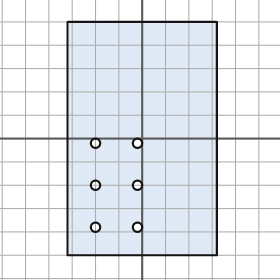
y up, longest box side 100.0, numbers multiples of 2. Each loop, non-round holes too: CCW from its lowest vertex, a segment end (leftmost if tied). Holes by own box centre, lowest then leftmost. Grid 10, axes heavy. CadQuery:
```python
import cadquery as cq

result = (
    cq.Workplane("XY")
    .moveTo(-32.0, -50.0)
    .lineTo(32.0, -50.0)
    .lineTo(32.0, 50.0)
    .lineTo(-32.0, 50.0)
    .close()
    .moveTo(-20.0, -38.0)
    .circle(2.0)
    .moveTo(-2.0, -38.0)
    .circle(2.0)
    .moveTo(-20.0, -20.0)
    .circle(2.0)
    .moveTo(-2.0, -20.0)
    .circle(2.0)
    .moveTo(-20.0, -2.0)
    .circle(2.0)
    .moveTo(-2.0, -2.0)
    .circle(2.0)
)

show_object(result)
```